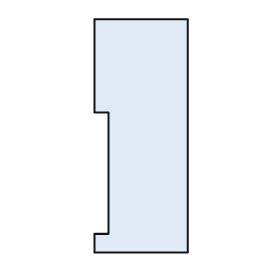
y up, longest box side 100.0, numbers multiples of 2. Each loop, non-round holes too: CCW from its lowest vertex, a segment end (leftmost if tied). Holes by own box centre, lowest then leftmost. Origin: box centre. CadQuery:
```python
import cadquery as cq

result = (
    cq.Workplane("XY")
    .moveTo(-20.0, -50.0)
    .lineTo(20.0, -50.0)
    .lineTo(20.0, 50.0)
    .lineTo(-20.0, 50.0)
    .lineTo(-20.0, 10.0)
    .lineTo(-14.0, 10.0)
    .lineTo(-14.0, -42.0)
    .lineTo(-20.0, -42.0)
    .close()
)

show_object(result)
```